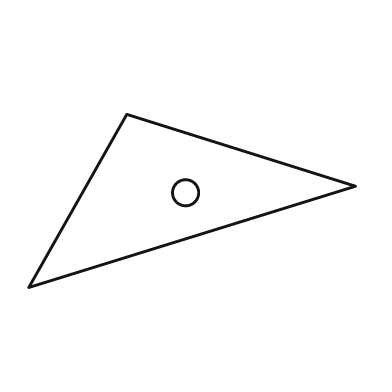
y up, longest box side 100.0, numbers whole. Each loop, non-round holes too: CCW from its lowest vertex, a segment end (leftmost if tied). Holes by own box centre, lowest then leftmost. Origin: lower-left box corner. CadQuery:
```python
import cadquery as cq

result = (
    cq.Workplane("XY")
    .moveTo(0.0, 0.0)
    .lineTo(100.0, 31.0)
    .lineTo(30.0, 53.0)
    .close()
    .moveTo(48.0, 29.0)
    .circle(4.0)
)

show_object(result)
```